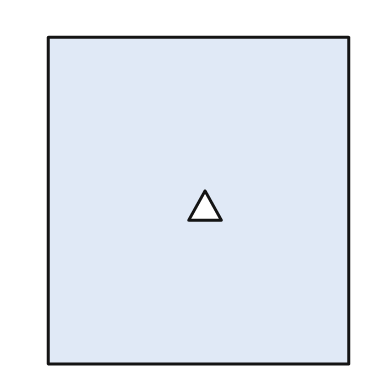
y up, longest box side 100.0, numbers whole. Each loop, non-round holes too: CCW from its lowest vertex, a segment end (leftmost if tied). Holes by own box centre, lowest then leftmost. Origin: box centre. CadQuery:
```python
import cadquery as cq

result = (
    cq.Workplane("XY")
    .moveTo(-46.0, -50.0)
    .lineTo(46.0, -50.0)
    .lineTo(46.0, 50.0)
    .lineTo(-46.0, 50.0)
    .close()
    .moveTo(-3.0, -6.0)
    .lineTo(7.0, -6.0)
    .lineTo(2.0, 3.0)
    .close()
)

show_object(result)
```